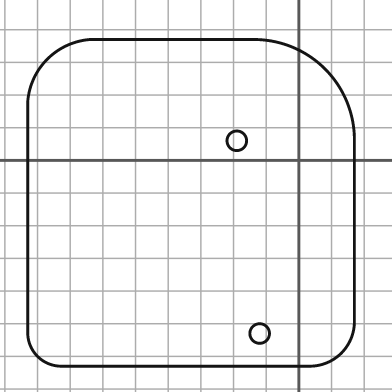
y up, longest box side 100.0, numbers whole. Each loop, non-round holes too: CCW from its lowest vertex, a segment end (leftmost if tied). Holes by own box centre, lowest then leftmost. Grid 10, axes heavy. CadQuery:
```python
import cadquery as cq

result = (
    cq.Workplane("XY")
    .moveTo(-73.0, -63.0)
    .lineTo(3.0, -63.0)
    .threePointArc((13.0, -59.0), (17.0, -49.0))
    .lineTo(17.0, 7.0)
    .threePointArc((8.0, 28.0), (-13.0, 37.0))
    .lineTo(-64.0, 37.0)
    .threePointArc((-77.0, 31.0), (-83.0, 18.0))
    .lineTo(-83.0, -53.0)
    .threePointArc((-80.0, -60.0), (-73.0, -63.0))
    .close()
    .moveTo(-12.0, -53.0)
    .circle(3.0)
    .moveTo(-19.0, 6.0)
    .circle(3.0)
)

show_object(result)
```